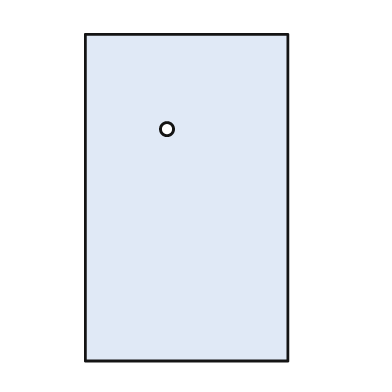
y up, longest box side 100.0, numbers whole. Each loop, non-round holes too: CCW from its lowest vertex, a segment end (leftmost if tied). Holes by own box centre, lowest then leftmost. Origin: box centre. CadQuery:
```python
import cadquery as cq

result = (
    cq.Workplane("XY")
    .moveTo(-31.0, -50.0)
    .lineTo(31.0, -50.0)
    .lineTo(31.0, 50.0)
    .lineTo(-31.0, 50.0)
    .close()
    .moveTo(-6.0, 21.0)
    .circle(2.0)
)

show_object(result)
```